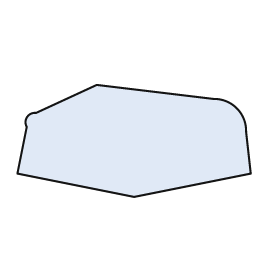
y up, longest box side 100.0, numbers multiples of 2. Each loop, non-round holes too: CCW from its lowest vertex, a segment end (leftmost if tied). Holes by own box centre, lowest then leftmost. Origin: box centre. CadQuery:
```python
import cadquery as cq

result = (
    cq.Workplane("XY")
    .moveTo(0.0, -24.0)
    .lineTo(50.0, -14.0)
    .lineTo(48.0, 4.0)
    .threePointArc((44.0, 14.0), (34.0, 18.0))
    .lineTo(-16.0, 24.0)
    .lineTo(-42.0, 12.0)
    .threePointArc((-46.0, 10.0), (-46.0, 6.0))
    .lineTo(-50.0, -14.0)
    .close()
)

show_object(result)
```